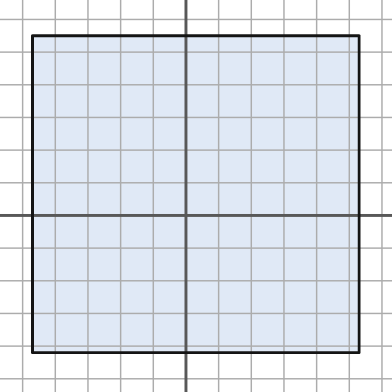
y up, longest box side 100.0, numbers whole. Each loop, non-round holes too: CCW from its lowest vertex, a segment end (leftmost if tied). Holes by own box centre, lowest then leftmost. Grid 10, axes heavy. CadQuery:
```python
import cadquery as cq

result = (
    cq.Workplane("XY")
    .moveTo(-47.0, -42.0)
    .lineTo(53.0, -42.0)
    .lineTo(53.0, 55.0)
    .lineTo(-47.0, 55.0)
    .close()
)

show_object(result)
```